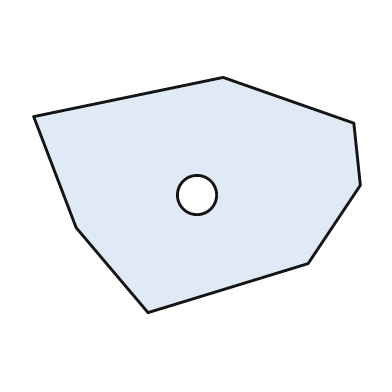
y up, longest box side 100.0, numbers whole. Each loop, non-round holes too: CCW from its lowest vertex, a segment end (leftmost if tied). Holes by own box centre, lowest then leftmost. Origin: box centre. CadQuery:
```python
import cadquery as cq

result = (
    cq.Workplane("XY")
    .moveTo(-15.0, -36.0)
    .lineTo(34.0, -21.0)
    .lineTo(50.0, 3.0)
    .lineTo(48.0, 22.0)
    .lineTo(8.0, 36.0)
    .lineTo(-50.0, 24.0)
    .lineTo(-37.0, -10.0)
    .close()
    .moveTo(0.0, 0.0)
    .circle(6.0)
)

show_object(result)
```